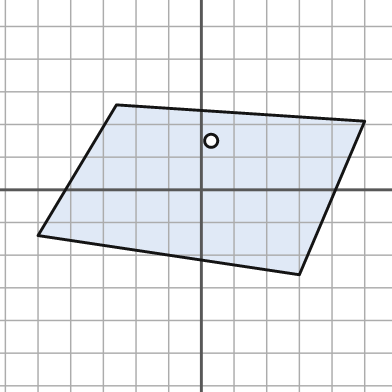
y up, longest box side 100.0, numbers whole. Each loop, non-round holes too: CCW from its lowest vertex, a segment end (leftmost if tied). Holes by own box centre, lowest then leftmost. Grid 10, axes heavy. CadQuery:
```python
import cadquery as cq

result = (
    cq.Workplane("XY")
    .moveTo(30.0, -26.0)
    .lineTo(50.0, 21.0)
    .lineTo(-26.0, 26.0)
    .lineTo(-50.0, -14.0)
    .close()
    .moveTo(3.0, 15.0)
    .circle(2.0)
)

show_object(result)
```